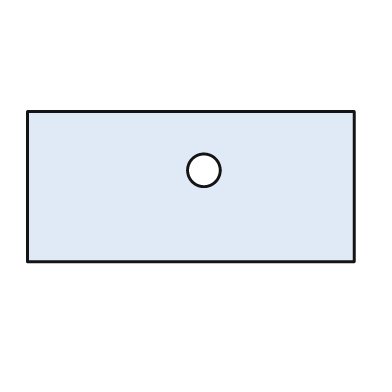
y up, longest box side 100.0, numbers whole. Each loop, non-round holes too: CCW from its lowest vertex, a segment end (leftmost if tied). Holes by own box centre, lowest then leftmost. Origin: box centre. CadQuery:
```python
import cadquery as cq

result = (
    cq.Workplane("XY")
    .moveTo(-50.0, -23.0)
    .lineTo(50.0, -23.0)
    .lineTo(50.0, 23.0)
    .lineTo(-50.0, 23.0)
    .close()
    .moveTo(4.0, 5.0)
    .circle(5.0)
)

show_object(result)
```